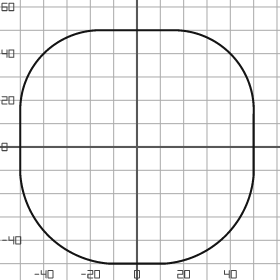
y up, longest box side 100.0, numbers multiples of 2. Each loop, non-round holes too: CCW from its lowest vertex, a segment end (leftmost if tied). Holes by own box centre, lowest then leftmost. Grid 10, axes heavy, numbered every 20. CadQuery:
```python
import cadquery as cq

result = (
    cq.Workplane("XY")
    .moveTo(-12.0, -50.0)
    .lineTo(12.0, -50.0)
    .threePointArc((38.0, -38.0), (50.0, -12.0))
    .lineTo(50.0, 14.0)
    .threePointArc((40.0, 40.0), (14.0, 50.0))
    .lineTo(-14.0, 50.0)
    .threePointArc((-40.0, 40.0), (-50.0, 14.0))
    .lineTo(-50.0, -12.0)
    .threePointArc((-38.0, -38.0), (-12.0, -50.0))
    .close()
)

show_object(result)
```